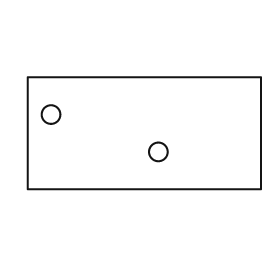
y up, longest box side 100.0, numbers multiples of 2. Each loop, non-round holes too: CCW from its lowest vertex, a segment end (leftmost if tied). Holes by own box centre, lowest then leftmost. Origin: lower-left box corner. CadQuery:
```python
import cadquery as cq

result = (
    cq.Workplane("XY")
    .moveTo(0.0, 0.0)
    .lineTo(100.0, 0.0)
    .lineTo(100.0, 48.0)
    .lineTo(0.0, 48.0)
    .close()
    .moveTo(56.0, 16.0)
    .circle(4.0)
    .moveTo(10.0, 32.0)
    .circle(4.0)
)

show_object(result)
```